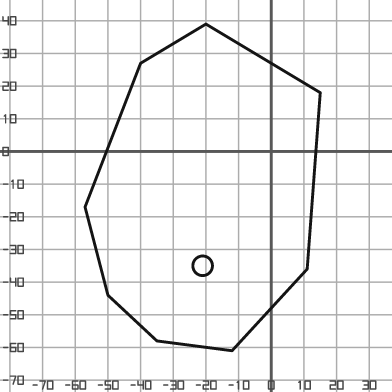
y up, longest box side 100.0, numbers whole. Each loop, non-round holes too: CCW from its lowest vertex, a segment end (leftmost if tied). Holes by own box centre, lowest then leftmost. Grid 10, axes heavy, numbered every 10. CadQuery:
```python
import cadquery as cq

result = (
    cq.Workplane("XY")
    .moveTo(-12.0, -61.0)
    .lineTo(11.0, -36.0)
    .lineTo(15.0, 18.0)
    .lineTo(-20.0, 39.0)
    .lineTo(-40.0, 27.0)
    .lineTo(-57.0, -17.0)
    .lineTo(-50.0, -44.0)
    .lineTo(-35.0, -58.0)
    .close()
    .moveTo(-21.0, -35.0)
    .circle(3.0)
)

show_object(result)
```